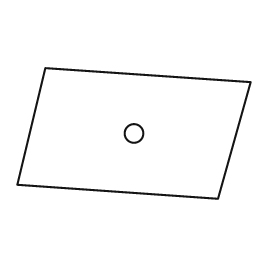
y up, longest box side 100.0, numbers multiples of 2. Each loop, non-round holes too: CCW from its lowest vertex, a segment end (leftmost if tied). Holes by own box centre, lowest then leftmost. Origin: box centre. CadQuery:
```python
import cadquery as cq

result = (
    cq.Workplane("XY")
    .moveTo(36.0, -28.0)
    .lineTo(50.0, 22.0)
    .lineTo(-38.0, 28.0)
    .lineTo(-50.0, -22.0)
    .close()
    .moveTo(0.0, 0.0)
    .circle(4.0)
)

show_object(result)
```